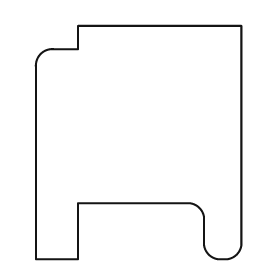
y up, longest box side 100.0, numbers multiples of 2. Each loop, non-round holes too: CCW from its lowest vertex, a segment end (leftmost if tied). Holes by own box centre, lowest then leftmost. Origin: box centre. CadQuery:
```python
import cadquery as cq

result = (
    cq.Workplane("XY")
    .moveTo(-44.0, -50.0)
    .lineTo(-26.0, -50.0)
    .lineTo(-26.0, -26.0)
    .lineTo(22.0, -26.0)
    .threePointArc((26.0, -28.0), (28.0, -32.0))
    .lineTo(28.0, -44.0)
    .threePointArc((30.0, -48.0), (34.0, -50.0))
    .lineTo(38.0, -50.0)
    .threePointArc((42.0, -48.0), (44.0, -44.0))
    .lineTo(44.0, 50.0)
    .lineTo(-26.0, 50.0)
    .lineTo(-26.0, 40.0)
    .lineTo(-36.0, 40.0)
    .threePointArc((-42.0, 38.0), (-44.0, 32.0))
    .close()
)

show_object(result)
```